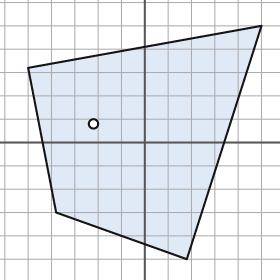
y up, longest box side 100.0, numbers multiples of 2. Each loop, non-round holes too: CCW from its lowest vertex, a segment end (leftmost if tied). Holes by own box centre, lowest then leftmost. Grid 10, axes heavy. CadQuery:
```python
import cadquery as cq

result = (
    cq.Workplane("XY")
    .moveTo(18.0, -50.0)
    .lineTo(50.0, 50.0)
    .lineTo(-50.0, 32.0)
    .lineTo(-38.0, -30.0)
    .close()
    .moveTo(-22.0, 8.0)
    .circle(2.0)
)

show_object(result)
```